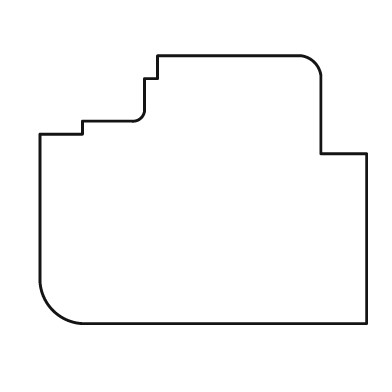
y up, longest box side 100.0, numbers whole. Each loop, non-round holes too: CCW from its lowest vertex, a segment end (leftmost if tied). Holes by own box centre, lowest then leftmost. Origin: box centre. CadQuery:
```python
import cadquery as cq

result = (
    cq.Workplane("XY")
    .moveTo(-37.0, -41.0)
    .lineTo(50.0, -41.0)
    .lineTo(50.0, 11.0)
    .lineTo(36.0, 11.0)
    .lineTo(36.0, 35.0)
    .threePointArc((34.0, 39.0), (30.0, 41.0))
    .lineTo(-14.0, 41.0)
    .lineTo(-14.0, 34.0)
    .lineTo(-18.0, 34.0)
    .lineTo(-18.0, 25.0)
    .threePointArc((-19.0, 22.0), (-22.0, 21.0))
    .lineTo(-37.0, 21.0)
    .lineTo(-37.0, 17.0)
    .lineTo(-50.0, 17.0)
    .lineTo(-50.0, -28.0)
    .threePointArc((-46.0, -37.0), (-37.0, -41.0))
    .close()
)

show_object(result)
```